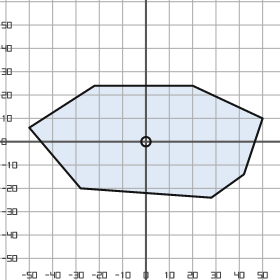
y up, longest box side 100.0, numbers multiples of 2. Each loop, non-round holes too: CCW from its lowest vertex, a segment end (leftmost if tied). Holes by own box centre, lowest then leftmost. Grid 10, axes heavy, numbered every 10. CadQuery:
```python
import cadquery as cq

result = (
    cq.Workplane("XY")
    .moveTo(28.0, -24.0)
    .lineTo(42.0, -14.0)
    .lineTo(50.0, 10.0)
    .lineTo(20.0, 24.0)
    .lineTo(-22.0, 24.0)
    .lineTo(-50.0, 6.0)
    .lineTo(-28.0, -20.0)
    .close()
    .moveTo(0.0, 0.0)
    .circle(2.0)
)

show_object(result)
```